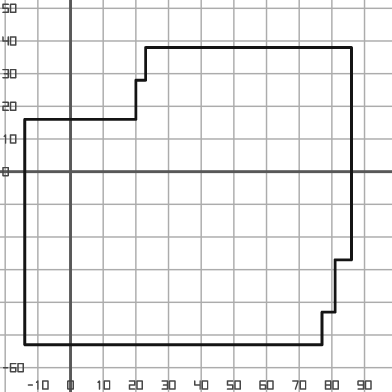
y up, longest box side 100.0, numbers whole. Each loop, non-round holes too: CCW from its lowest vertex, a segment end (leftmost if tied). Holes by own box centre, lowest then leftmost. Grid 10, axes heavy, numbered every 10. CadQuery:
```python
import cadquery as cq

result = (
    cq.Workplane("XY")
    .moveTo(-14.0, -53.0)
    .lineTo(77.0, -53.0)
    .lineTo(77.0, -43.0)
    .lineTo(81.0, -43.0)
    .lineTo(81.0, -27.0)
    .lineTo(86.0, -27.0)
    .lineTo(86.0, 38.0)
    .lineTo(23.0, 38.0)
    .lineTo(23.0, 28.0)
    .lineTo(20.0, 28.0)
    .lineTo(20.0, 16.0)
    .lineTo(-14.0, 16.0)
    .close()
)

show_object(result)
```